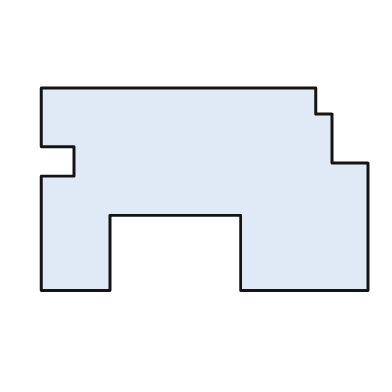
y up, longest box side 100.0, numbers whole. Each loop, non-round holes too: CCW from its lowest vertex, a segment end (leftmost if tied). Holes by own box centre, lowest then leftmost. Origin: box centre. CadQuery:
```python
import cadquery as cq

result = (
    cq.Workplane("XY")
    .moveTo(-50.0, -31.0)
    .lineTo(-29.0, -31.0)
    .lineTo(-29.0, -8.0)
    .lineTo(11.0, -8.0)
    .lineTo(11.0, -31.0)
    .lineTo(50.0, -31.0)
    .lineTo(50.0, 8.0)
    .lineTo(39.0, 8.0)
    .lineTo(39.0, 23.0)
    .lineTo(34.0, 23.0)
    .lineTo(34.0, 31.0)
    .lineTo(-50.0, 31.0)
    .lineTo(-50.0, 13.0)
    .lineTo(-40.0, 13.0)
    .lineTo(-40.0, 4.0)
    .lineTo(-50.0, 4.0)
    .close()
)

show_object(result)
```